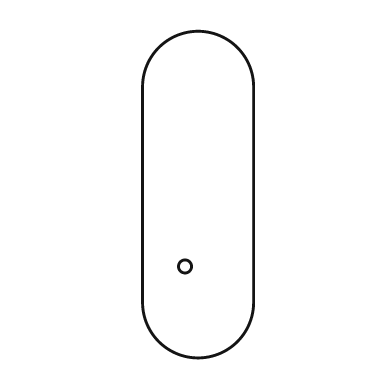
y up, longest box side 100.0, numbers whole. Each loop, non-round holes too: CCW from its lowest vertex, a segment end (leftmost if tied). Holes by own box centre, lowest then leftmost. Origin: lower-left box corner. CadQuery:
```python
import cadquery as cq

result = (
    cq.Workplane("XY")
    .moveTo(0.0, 17.0)
    .threePointArc((17.0, 0.0), (34.0, 17.0))
    .lineTo(34.0, 83.0)
    .threePointArc((17.0, 100.0), (0.0, 83.0))
    .close()
    .moveTo(13.0, 28.0)
    .circle(2.0)
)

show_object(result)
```